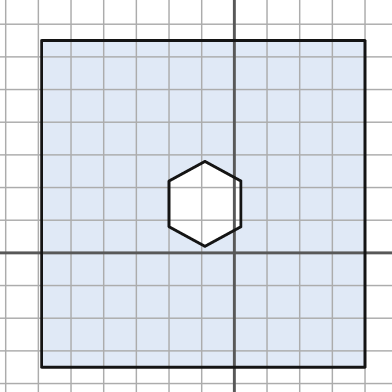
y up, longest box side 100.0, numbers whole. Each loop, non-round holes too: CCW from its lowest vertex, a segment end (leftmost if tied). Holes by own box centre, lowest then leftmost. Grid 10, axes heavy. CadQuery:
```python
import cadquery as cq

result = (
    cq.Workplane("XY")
    .moveTo(-59.0, -35.0)
    .lineTo(40.0, -35.0)
    .lineTo(40.0, 65.0)
    .lineTo(-59.0, 65.0)
    .close()
    .moveTo(-9.0, 2.0)
    .lineTo(2.0, 8.0)
    .lineTo(2.0, 22.0)
    .lineTo(-9.0, 28.0)
    .lineTo(-20.0, 22.0)
    .lineTo(-20.0, 8.0)
    .close()
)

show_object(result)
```